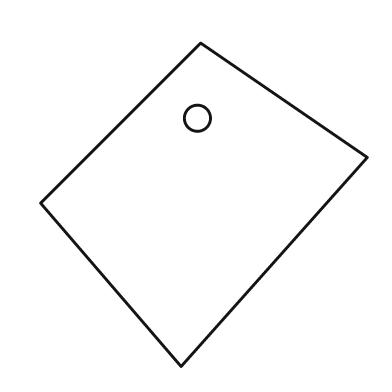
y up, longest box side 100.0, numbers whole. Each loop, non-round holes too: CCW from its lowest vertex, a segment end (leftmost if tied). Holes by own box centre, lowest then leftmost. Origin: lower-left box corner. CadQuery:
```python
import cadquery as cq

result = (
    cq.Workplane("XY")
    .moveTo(43.0, 0.0)
    .lineTo(100.0, 64.0)
    .lineTo(49.0, 99.0)
    .lineTo(0.0, 50.0)
    .close()
    .moveTo(48.0, 76.0)
    .circle(4.0)
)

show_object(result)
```